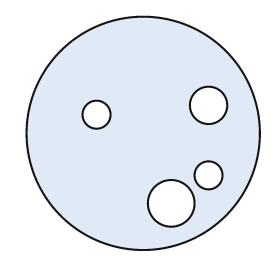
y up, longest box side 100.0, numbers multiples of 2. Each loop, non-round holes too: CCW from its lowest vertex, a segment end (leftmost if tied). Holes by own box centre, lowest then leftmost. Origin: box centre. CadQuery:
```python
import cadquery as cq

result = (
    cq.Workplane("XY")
    .moveTo(0.0, 0.0)
    .circle(50.0)
    .moveTo(12.0, -30.0)
    .circle(10.0)
    .moveTo(28.0, -18.0)
    .circle(6.0)
    .moveTo(-20.0, 8.0)
    .circle(6.0)
    .moveTo(28.0, 12.0)
    .circle(8.0)
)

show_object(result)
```